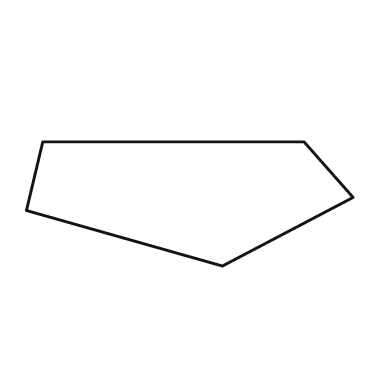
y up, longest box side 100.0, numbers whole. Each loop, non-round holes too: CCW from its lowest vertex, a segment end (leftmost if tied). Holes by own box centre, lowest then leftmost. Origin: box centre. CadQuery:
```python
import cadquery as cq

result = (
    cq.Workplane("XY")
    .moveTo(10.0, -19.0)
    .lineTo(50.0, 2.0)
    .lineTo(35.0, 19.0)
    .lineTo(-45.0, 19.0)
    .lineTo(-50.0, -2.0)
    .close()
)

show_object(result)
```